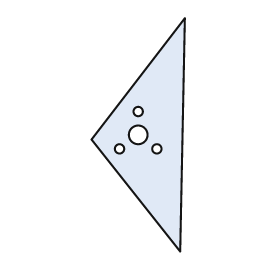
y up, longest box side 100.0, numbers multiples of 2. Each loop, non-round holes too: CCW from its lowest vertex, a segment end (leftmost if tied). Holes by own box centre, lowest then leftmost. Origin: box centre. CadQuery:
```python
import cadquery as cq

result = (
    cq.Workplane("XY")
    .moveTo(18.0, -50.0)
    .lineTo(20.0, 50.0)
    .lineTo(-20.0, -2.0)
    .close()
    .moveTo(-8.0, -6.0)
    .circle(2.0)
    .moveTo(8.0, -6.0)
    .circle(2.0)
    .moveTo(0.0, 0.0)
    .circle(4.0)
    .moveTo(0.0, 10.0)
    .circle(2.0)
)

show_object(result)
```